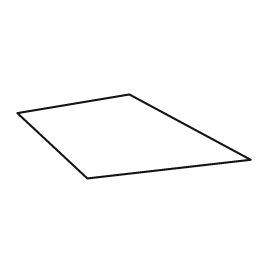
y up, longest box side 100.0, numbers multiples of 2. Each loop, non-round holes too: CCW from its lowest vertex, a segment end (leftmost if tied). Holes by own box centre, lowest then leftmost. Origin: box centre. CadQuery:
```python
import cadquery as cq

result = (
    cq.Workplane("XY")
    .moveTo(-20.0, -18.0)
    .lineTo(50.0, -10.0)
    .lineTo(-2.0, 18.0)
    .lineTo(-50.0, 10.0)
    .close()
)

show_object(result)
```